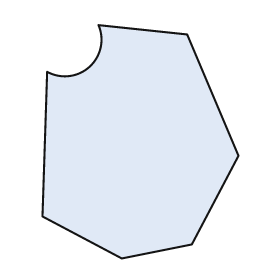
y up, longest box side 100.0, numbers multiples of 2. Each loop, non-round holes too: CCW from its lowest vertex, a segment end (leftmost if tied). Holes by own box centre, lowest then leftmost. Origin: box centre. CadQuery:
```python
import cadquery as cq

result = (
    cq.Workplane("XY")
    .moveTo(-8.0, -50.0)
    .lineTo(22.0, -44.0)
    .lineTo(42.0, -6.0)
    .lineTo(20.0, 46.0)
    .lineTo(-18.0, 50.0)
    .threePointArc((-22.0, 32.0), (-40.0, 30.0))
    .lineTo(-42.0, -32.0)
    .close()
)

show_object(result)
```